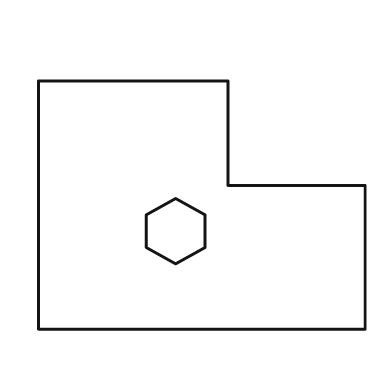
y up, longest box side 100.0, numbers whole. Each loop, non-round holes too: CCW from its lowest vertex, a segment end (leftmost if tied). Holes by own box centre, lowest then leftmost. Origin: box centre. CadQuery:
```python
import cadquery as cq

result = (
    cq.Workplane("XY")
    .moveTo(-50.0, -38.0)
    .lineTo(50.0, -38.0)
    .lineTo(50.0, 6.0)
    .lineTo(8.0, 6.0)
    .lineTo(8.0, 38.0)
    .lineTo(-50.0, 38.0)
    .close()
    .moveTo(-8.0, -18.0)
    .lineTo(1.0, -13.0)
    .lineTo(1.0, -3.0)
    .lineTo(-8.0, 2.0)
    .lineTo(-17.0, -3.0)
    .lineTo(-17.0, -13.0)
    .close()
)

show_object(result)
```